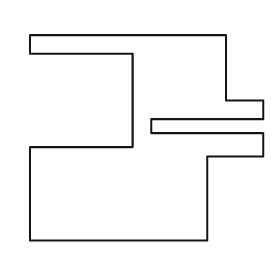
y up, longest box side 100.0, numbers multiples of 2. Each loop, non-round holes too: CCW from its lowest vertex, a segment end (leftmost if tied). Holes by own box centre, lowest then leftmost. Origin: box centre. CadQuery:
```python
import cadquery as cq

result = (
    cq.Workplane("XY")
    .moveTo(-50.0, -44.0)
    .lineTo(26.0, -44.0)
    .lineTo(26.0, -8.0)
    .lineTo(50.0, -8.0)
    .lineTo(50.0, 2.0)
    .lineTo(2.0, 2.0)
    .lineTo(2.0, 8.0)
    .lineTo(50.0, 8.0)
    .lineTo(50.0, 16.0)
    .lineTo(34.0, 16.0)
    .lineTo(34.0, 44.0)
    .lineTo(-50.0, 44.0)
    .lineTo(-50.0, 36.0)
    .lineTo(-6.0, 36.0)
    .lineTo(-6.0, -4.0)
    .lineTo(-50.0, -4.0)
    .close()
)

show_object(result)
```